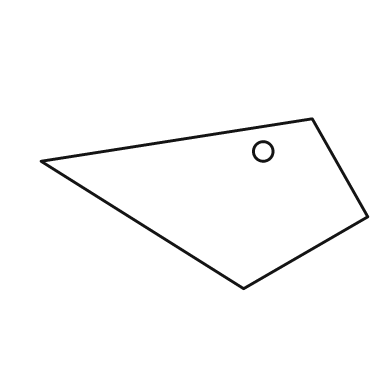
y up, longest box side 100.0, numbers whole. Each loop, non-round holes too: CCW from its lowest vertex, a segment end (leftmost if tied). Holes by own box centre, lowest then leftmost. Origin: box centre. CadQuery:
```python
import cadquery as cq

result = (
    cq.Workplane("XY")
    .moveTo(12.0, -26.0)
    .lineTo(50.0, -4.0)
    .lineTo(33.0, 26.0)
    .lineTo(-50.0, 13.0)
    .close()
    .moveTo(18.0, 16.0)
    .circle(3.0)
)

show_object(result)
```